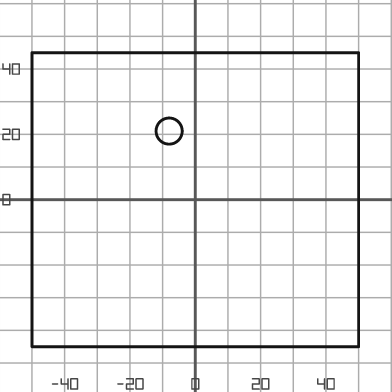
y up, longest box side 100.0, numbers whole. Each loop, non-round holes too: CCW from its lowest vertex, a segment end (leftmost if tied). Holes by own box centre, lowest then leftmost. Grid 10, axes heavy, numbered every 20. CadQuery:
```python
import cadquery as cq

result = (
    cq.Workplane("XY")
    .moveTo(-50.0, -45.0)
    .lineTo(50.0, -45.0)
    .lineTo(50.0, 45.0)
    .lineTo(-50.0, 45.0)
    .close()
    .moveTo(-8.0, 21.0)
    .circle(4.0)
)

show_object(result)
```